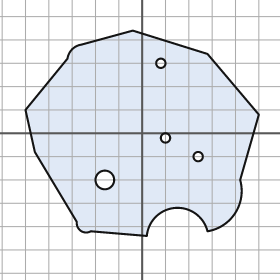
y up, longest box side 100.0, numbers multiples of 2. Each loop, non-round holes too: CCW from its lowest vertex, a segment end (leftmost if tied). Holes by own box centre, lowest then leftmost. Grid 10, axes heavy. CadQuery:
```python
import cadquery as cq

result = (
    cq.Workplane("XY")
    .moveTo(2.0, -44.0)
    .threePointArc((14.0, -32.0), (28.0, -42.0))
    .threePointArc((40.0, -34.0), (42.0, -20.0))
    .lineTo(50.0, 8.0)
    .lineTo(28.0, 34.0)
    .lineTo(-4.0, 44.0)
    .lineTo(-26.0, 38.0)
    .threePointArc((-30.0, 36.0), (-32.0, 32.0))
    .lineTo(-50.0, 10.0)
    .lineTo(-46.0, -8.0)
    .lineTo(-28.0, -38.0)
    .threePointArc((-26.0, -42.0), (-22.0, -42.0))
    .close()
    .moveTo(-16.0, -20.0)
    .circle(4.0)
    .moveTo(24.0, -10.0)
    .circle(2.0)
    .moveTo(10.0, -2.0)
    .circle(2.0)
    .moveTo(8.0, 30.0)
    .circle(2.0)
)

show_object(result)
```